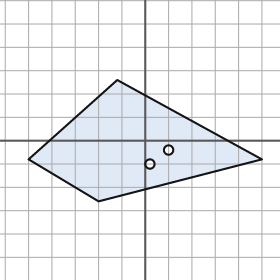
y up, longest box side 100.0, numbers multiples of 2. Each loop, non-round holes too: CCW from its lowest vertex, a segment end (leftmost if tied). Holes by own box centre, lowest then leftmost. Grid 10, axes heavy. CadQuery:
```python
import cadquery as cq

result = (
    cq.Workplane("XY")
    .moveTo(-20.0, -26.0)
    .lineTo(50.0, -8.0)
    .lineTo(-12.0, 26.0)
    .lineTo(-50.0, -8.0)
    .close()
    .moveTo(2.0, -10.0)
    .circle(2.0)
    .moveTo(10.0, -4.0)
    .circle(2.0)
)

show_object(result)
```